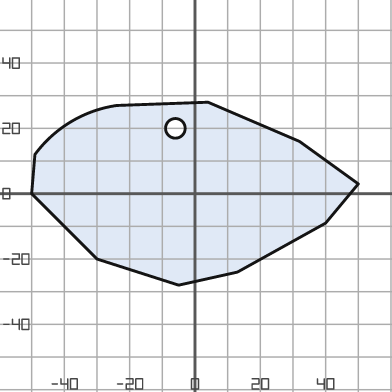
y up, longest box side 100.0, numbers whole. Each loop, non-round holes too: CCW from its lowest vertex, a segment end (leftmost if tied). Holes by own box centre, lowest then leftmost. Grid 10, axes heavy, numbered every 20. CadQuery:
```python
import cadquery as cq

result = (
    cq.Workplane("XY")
    .moveTo(-5.0, -28.0)
    .lineTo(13.0, -24.0)
    .lineTo(40.0, -9.0)
    .lineTo(50.0, 3.0)
    .lineTo(32.0, 16.0)
    .lineTo(4.0, 28.0)
    .lineTo(-24.0, 27.0)
    .threePointArc((-38.0, 22.0), (-49.0, 12.0))
    .lineTo(-50.0, 0.0)
    .lineTo(-30.0, -20.0)
    .close()
    .moveTo(-6.0, 20.0)
    .circle(3.0)
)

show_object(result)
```